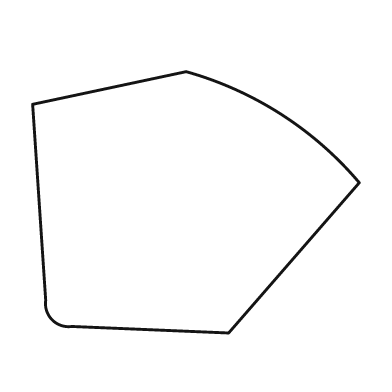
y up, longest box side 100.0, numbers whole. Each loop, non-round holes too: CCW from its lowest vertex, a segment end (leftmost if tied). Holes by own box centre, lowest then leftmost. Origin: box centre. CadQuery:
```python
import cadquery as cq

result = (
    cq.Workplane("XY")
    .moveTo(10.0, -40.0)
    .lineTo(50.0, 6.0)
    .threePointArc((26.0, 27.0), (-3.0, 40.0))
    .lineTo(-50.0, 30.0)
    .lineTo(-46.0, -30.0)
    .threePointArc((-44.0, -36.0), (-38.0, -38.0))
    .close()
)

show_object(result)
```